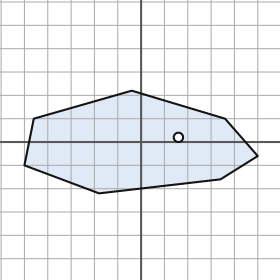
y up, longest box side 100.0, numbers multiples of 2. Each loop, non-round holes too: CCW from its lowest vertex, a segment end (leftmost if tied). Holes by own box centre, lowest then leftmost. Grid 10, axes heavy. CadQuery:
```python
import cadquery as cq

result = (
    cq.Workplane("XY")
    .moveTo(-18.0, -22.0)
    .lineTo(34.0, -16.0)
    .lineTo(50.0, -6.0)
    .lineTo(36.0, 10.0)
    .lineTo(-4.0, 22.0)
    .lineTo(-46.0, 10.0)
    .lineTo(-50.0, -10.0)
    .close()
    .moveTo(16.0, 2.0)
    .circle(2.0)
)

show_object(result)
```